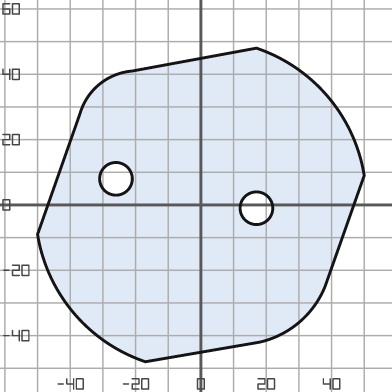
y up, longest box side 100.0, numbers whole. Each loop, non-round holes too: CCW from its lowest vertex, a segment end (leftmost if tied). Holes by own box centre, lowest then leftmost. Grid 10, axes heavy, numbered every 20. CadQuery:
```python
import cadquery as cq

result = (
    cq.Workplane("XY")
    .moveTo(-17.0, -48.0)
    .lineTo(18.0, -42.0)
    .threePointArc((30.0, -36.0), (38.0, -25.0))
    .lineTo(50.0, 9.0)
    .threePointArc((39.0, 33.0), (17.0, 48.0))
    .lineTo(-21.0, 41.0)
    .threePointArc((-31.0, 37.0), (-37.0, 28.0))
    .lineTo(-50.0, -9.0)
    .threePointArc((-39.0, -33.0), (-17.0, -48.0))
    .close()
    .moveTo(17.0, -1.0)
    .circle(5.0)
    .moveTo(-26.0, 8.0)
    .circle(5.0)
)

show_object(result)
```